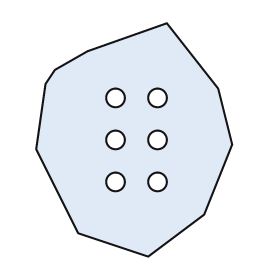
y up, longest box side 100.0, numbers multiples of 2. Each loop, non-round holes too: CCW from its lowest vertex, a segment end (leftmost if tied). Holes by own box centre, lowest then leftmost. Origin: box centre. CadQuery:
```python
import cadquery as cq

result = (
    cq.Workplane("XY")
    .moveTo(6.0, -50.0)
    .lineTo(30.0, -32.0)
    .lineTo(42.0, -2.0)
    .lineTo(36.0, 22.0)
    .lineTo(14.0, 50.0)
    .lineTo(-20.0, 38.0)
    .lineTo(-34.0, 30.0)
    .lineTo(-38.0, 24.0)
    .lineTo(-42.0, -4.0)
    .lineTo(-24.0, -40.0)
    .close()
    .moveTo(-8.0, -18.0)
    .circle(4.0)
    .moveTo(10.0, -18.0)
    .circle(4.0)
    .moveTo(-8.0, 0.0)
    .circle(4.0)
    .moveTo(10.0, 0.0)
    .circle(4.0)
    .moveTo(-8.0, 18.0)
    .circle(4.0)
    .moveTo(10.0, 18.0)
    .circle(4.0)
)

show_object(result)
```